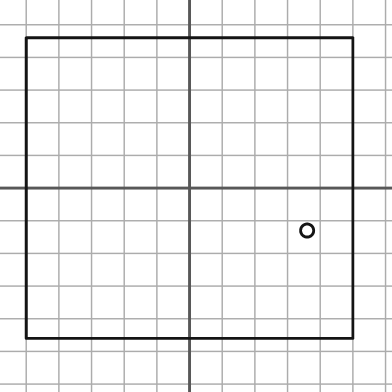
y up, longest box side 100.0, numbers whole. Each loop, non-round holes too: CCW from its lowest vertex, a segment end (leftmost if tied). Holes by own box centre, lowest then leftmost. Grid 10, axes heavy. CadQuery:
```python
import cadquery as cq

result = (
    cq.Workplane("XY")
    .moveTo(-50.0, -46.0)
    .lineTo(50.0, -46.0)
    .lineTo(50.0, 46.0)
    .lineTo(-50.0, 46.0)
    .close()
    .moveTo(36.0, -13.0)
    .circle(2.0)
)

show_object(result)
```